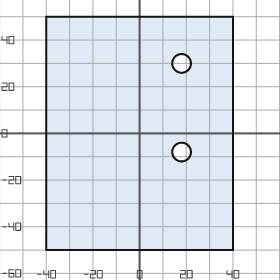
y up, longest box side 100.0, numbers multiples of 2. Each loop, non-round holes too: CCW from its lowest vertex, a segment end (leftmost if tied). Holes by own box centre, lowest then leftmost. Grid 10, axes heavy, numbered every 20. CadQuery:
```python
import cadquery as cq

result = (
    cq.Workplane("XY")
    .moveTo(-40.0, -50.0)
    .lineTo(40.0, -50.0)
    .lineTo(40.0, 50.0)
    .lineTo(-40.0, 50.0)
    .close()
    .moveTo(18.0, -8.0)
    .circle(4.0)
    .moveTo(18.0, 30.0)
    .circle(4.0)
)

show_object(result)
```